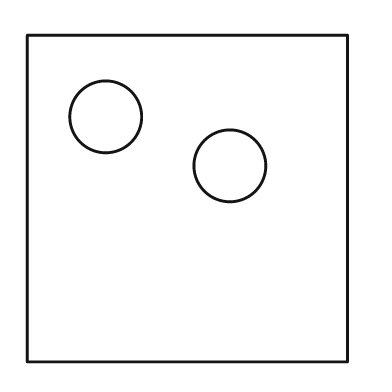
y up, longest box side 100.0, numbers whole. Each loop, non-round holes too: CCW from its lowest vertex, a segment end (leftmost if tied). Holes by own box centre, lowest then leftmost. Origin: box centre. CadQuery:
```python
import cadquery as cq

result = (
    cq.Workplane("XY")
    .moveTo(-49.0, -50.0)
    .lineTo(49.0, -50.0)
    .lineTo(49.0, 50.0)
    .lineTo(-49.0, 50.0)
    .close()
    .moveTo(13.0, 10.0)
    .circle(11.0)
    .moveTo(-25.0, 25.0)
    .circle(11.0)
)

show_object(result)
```